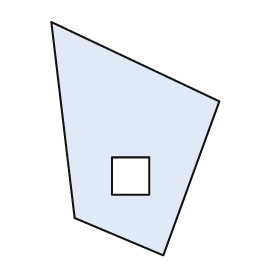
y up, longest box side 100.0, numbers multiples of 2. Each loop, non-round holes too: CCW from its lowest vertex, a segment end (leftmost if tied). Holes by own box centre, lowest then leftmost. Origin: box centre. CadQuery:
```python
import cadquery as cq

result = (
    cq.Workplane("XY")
    .moveTo(12.0, -50.0)
    .lineTo(36.0, 16.0)
    .lineTo(-36.0, 50.0)
    .lineTo(-26.0, -34.0)
    .close()
    .moveTo(-10.0, -24.0)
    .lineTo(6.0, -24.0)
    .lineTo(6.0, -8.0)
    .lineTo(-10.0, -8.0)
    .close()
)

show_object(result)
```